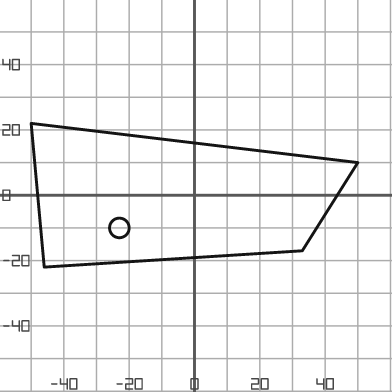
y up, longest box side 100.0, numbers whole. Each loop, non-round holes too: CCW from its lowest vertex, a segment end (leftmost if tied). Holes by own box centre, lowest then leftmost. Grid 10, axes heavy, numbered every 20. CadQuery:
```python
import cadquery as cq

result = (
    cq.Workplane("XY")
    .moveTo(-46.0, -22.0)
    .lineTo(33.0, -17.0)
    .lineTo(50.0, 10.0)
    .lineTo(-50.0, 22.0)
    .close()
    .moveTo(-23.0, -10.0)
    .circle(3.0)
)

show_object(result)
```